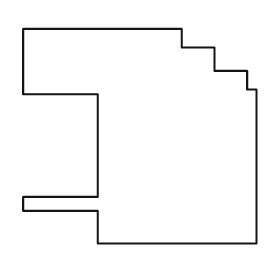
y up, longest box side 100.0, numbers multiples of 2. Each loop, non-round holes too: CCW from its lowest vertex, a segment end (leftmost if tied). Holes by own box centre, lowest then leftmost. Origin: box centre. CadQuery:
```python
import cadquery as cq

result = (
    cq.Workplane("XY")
    .moveTo(-18.0, -46.0)
    .lineTo(50.0, -46.0)
    .lineTo(50.0, 20.0)
    .lineTo(46.0, 20.0)
    .lineTo(46.0, 28.0)
    .lineTo(32.0, 28.0)
    .lineTo(32.0, 38.0)
    .lineTo(18.0, 38.0)
    .lineTo(18.0, 46.0)
    .lineTo(-50.0, 46.0)
    .lineTo(-50.0, 18.0)
    .lineTo(-18.0, 18.0)
    .lineTo(-18.0, -26.0)
    .lineTo(-50.0, -26.0)
    .lineTo(-50.0, -32.0)
    .lineTo(-18.0, -32.0)
    .close()
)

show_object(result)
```